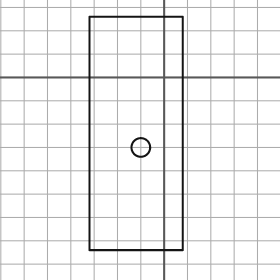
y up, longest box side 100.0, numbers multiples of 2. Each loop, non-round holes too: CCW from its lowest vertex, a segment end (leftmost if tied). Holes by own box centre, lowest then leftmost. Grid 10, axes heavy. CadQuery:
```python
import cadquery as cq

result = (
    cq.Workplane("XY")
    .moveTo(-32.0, -74.0)
    .lineTo(8.0, -74.0)
    .lineTo(8.0, 26.0)
    .lineTo(-32.0, 26.0)
    .close()
    .moveTo(-10.0, -30.0)
    .circle(4.0)
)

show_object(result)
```